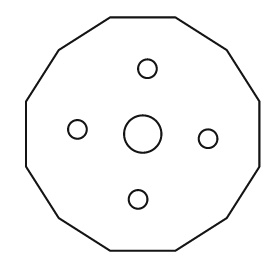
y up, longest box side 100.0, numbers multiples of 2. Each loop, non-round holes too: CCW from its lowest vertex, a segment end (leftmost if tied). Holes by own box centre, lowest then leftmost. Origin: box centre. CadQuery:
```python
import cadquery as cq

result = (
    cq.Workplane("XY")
    .moveTo(-14.0, -50.0)
    .lineTo(14.0, -50.0)
    .lineTo(36.0, -36.0)
    .lineTo(50.0, -14.0)
    .lineTo(50.0, 14.0)
    .lineTo(36.0, 36.0)
    .lineTo(14.0, 50.0)
    .lineTo(-14.0, 50.0)
    .lineTo(-36.0, 36.0)
    .lineTo(-50.0, 14.0)
    .lineTo(-50.0, -14.0)
    .lineTo(-36.0, -36.0)
    .close()
    .moveTo(-2.0, -28.0)
    .circle(4.0)
    .moveTo(28.0, -2.0)
    .circle(4.0)
    .moveTo(0.0, 0.0)
    .circle(8.0)
    .moveTo(-28.0, 2.0)
    .circle(4.0)
    .moveTo(2.0, 28.0)
    .circle(4.0)
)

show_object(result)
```